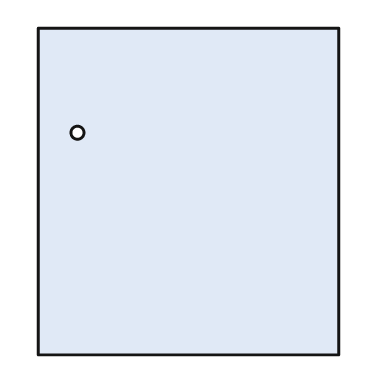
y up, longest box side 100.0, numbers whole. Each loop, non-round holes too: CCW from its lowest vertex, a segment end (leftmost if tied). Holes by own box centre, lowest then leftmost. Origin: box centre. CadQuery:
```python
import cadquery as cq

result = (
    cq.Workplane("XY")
    .moveTo(-46.0, -50.0)
    .lineTo(46.0, -50.0)
    .lineTo(46.0, 50.0)
    .lineTo(-46.0, 50.0)
    .close()
    .moveTo(-34.0, 18.0)
    .circle(2.0)
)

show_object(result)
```